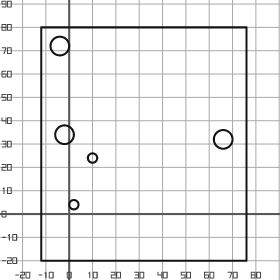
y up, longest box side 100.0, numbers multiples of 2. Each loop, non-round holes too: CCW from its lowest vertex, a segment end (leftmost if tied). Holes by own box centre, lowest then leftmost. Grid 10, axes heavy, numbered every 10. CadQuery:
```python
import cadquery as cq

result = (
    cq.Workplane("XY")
    .moveTo(-12.0, -20.0)
    .lineTo(76.0, -20.0)
    .lineTo(76.0, 80.0)
    .lineTo(-12.0, 80.0)
    .close()
    .moveTo(2.0, 4.0)
    .circle(2.0)
    .moveTo(10.0, 24.0)
    .circle(2.0)
    .moveTo(66.0, 32.0)
    .circle(4.0)
    .moveTo(-2.0, 34.0)
    .circle(4.0)
    .moveTo(-4.0, 72.0)
    .circle(4.0)
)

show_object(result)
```